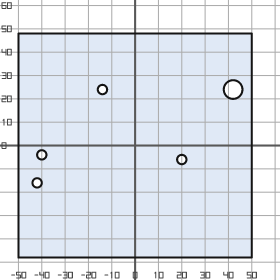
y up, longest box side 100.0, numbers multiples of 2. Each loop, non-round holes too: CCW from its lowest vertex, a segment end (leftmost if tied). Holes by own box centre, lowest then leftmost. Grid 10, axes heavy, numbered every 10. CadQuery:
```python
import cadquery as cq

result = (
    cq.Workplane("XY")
    .moveTo(-50.0, -48.0)
    .lineTo(50.0, -48.0)
    .lineTo(50.0, 48.0)
    .lineTo(-50.0, 48.0)
    .close()
    .moveTo(-42.0, -16.0)
    .circle(2.0)
    .moveTo(20.0, -6.0)
    .circle(2.0)
    .moveTo(-40.0, -4.0)
    .circle(2.0)
    .moveTo(-14.0, 24.0)
    .circle(2.0)
    .moveTo(42.0, 24.0)
    .circle(4.0)
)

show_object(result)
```